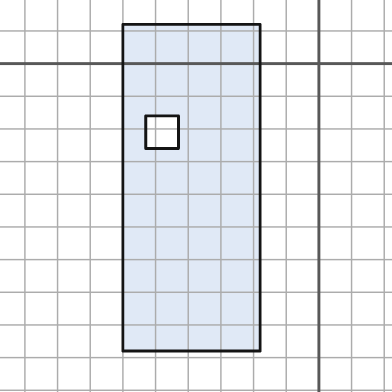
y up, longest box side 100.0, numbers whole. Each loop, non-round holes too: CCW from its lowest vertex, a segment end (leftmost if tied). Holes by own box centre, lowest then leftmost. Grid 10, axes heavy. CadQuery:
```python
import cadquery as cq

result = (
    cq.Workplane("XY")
    .moveTo(-60.0, -88.0)
    .lineTo(-18.0, -88.0)
    .lineTo(-18.0, 12.0)
    .lineTo(-60.0, 12.0)
    .close()
    .moveTo(-53.0, -26.0)
    .lineTo(-43.0, -26.0)
    .lineTo(-43.0, -16.0)
    .lineTo(-53.0, -16.0)
    .close()
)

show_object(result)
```